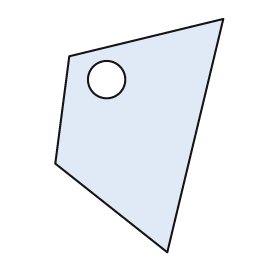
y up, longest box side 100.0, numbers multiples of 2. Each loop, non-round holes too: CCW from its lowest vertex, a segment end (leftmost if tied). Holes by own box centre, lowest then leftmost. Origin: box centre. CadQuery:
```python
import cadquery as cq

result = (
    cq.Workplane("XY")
    .moveTo(12.0, -50.0)
    .lineTo(36.0, 50.0)
    .lineTo(-30.0, 34.0)
    .lineTo(-36.0, -12.0)
    .close()
    .moveTo(-14.0, 24.0)
    .circle(8.0)
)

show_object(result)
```